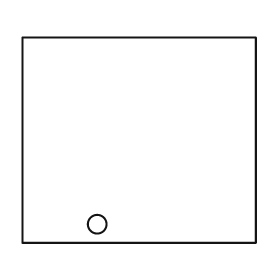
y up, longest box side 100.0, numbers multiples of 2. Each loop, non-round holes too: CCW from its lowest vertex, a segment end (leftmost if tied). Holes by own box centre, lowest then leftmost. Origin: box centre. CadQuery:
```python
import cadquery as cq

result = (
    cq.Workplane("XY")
    .moveTo(-50.0, -44.0)
    .lineTo(50.0, -44.0)
    .lineTo(50.0, 44.0)
    .lineTo(-50.0, 44.0)
    .close()
    .moveTo(-18.0, -36.0)
    .circle(4.0)
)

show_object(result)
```